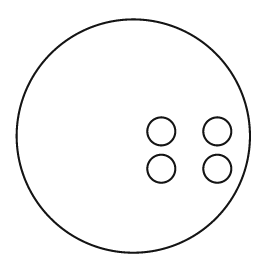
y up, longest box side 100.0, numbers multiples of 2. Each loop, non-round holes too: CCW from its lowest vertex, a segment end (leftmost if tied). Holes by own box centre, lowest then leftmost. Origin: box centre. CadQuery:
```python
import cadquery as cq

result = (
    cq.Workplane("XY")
    .moveTo(0.0, 0.0)
    .circle(50.0)
    .moveTo(12.0, -14.0)
    .circle(6.0)
    .moveTo(36.0, -14.0)
    .circle(6.0)
    .moveTo(12.0, 2.0)
    .circle(6.0)
    .moveTo(36.0, 2.0)
    .circle(6.0)
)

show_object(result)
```